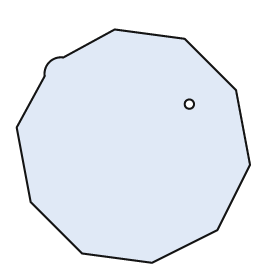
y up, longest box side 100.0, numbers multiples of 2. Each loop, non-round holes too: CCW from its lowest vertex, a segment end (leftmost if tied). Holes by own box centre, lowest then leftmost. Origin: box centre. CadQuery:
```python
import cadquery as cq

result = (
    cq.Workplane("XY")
    .moveTo(8.0, -50.0)
    .lineTo(36.0, -36.0)
    .lineTo(50.0, -8.0)
    .lineTo(44.0, 24.0)
    .lineTo(22.0, 46.0)
    .lineTo(-8.0, 50.0)
    .lineTo(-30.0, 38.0)
    .threePointArc((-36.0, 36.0), (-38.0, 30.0))
    .lineTo(-50.0, 8.0)
    .lineTo(-44.0, -24.0)
    .lineTo(-22.0, -46.0)
    .close()
    .moveTo(24.0, 18.0)
    .circle(2.0)
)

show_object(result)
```